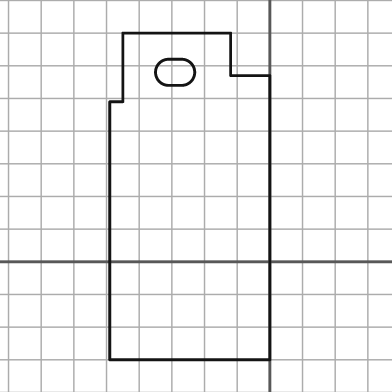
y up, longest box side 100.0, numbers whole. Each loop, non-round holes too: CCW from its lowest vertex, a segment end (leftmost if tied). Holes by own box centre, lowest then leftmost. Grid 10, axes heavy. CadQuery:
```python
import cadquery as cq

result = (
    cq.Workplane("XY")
    .moveTo(-49.0, -30.0)
    .lineTo(0.0, -30.0)
    .lineTo(0.0, 57.0)
    .lineTo(-12.0, 57.0)
    .lineTo(-12.0, 70.0)
    .lineTo(-45.0, 70.0)
    .lineTo(-45.0, 49.0)
    .lineTo(-49.0, 49.0)
    .close()
    .moveTo(-31.0, 54.0)
    .lineTo(-27.0, 54.0)
    .threePointArc((-23.0, 58.0), (-27.0, 62.0))
    .lineTo(-31.0, 62.0)
    .threePointArc((-35.0, 58.0), (-31.0, 54.0))
    .close()
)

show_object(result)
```